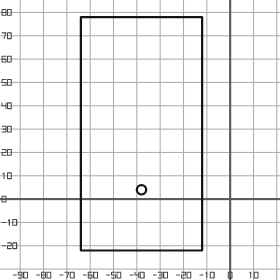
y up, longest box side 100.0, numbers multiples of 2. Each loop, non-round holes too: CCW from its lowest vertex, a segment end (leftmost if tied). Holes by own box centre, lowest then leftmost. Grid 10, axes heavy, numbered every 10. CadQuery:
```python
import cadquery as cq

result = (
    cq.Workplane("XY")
    .moveTo(-64.0, -22.0)
    .lineTo(-12.0, -22.0)
    .lineTo(-12.0, 78.0)
    .lineTo(-64.0, 78.0)
    .close()
    .moveTo(-38.0, 4.0)
    .circle(2.0)
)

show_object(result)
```